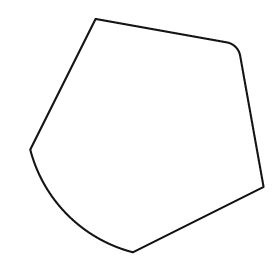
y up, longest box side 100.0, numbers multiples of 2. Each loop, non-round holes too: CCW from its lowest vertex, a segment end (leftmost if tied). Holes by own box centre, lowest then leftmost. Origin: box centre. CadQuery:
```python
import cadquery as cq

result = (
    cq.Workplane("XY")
    .moveTo(-6.0, -50.0)
    .lineTo(50.0, -22.0)
    .lineTo(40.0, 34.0)
    .threePointArc((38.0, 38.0), (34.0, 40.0))
    .lineTo(-22.0, 50.0)
    .lineTo(-50.0, -6.0)
    .threePointArc((-34.0, -34.0), (-6.0, -50.0))
    .close()
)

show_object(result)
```